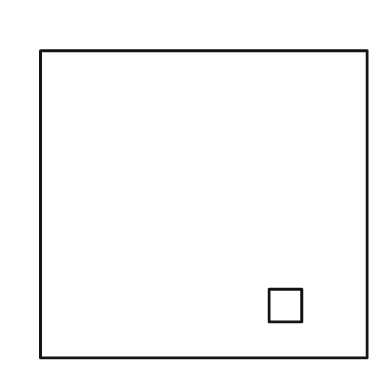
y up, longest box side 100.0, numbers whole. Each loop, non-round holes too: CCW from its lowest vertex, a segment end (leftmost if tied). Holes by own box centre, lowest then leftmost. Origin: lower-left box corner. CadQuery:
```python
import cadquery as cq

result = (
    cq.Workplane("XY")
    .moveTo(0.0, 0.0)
    .lineTo(100.0, 0.0)
    .lineTo(100.0, 94.0)
    .lineTo(0.0, 94.0)
    .close()
    .moveTo(70.0, 11.0)
    .lineTo(80.0, 11.0)
    .lineTo(80.0, 21.0)
    .lineTo(70.0, 21.0)
    .close()
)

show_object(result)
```